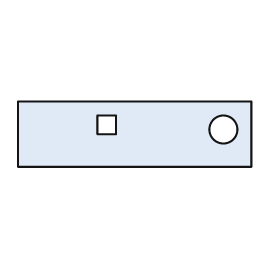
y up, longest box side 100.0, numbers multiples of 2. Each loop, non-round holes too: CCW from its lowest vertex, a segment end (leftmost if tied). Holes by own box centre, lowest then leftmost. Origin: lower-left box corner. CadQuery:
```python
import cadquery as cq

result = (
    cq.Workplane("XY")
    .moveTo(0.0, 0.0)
    .lineTo(100.0, 0.0)
    .lineTo(100.0, 28.0)
    .lineTo(0.0, 28.0)
    .close()
    .moveTo(88.0, 16.0)
    .circle(6.0)
    .moveTo(34.0, 14.0)
    .lineTo(42.0, 14.0)
    .lineTo(42.0, 22.0)
    .lineTo(34.0, 22.0)
    .close()
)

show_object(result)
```